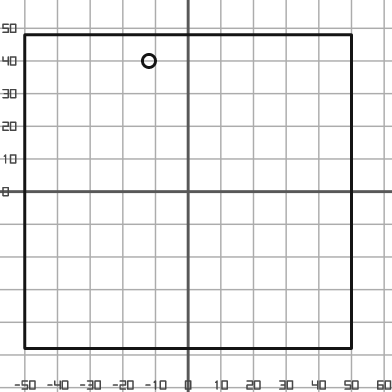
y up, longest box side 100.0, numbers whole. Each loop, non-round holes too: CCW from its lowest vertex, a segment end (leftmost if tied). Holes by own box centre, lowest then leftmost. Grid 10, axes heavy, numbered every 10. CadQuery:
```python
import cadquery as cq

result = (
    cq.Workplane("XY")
    .moveTo(-50.0, -48.0)
    .lineTo(50.0, -48.0)
    .lineTo(50.0, 48.0)
    .lineTo(-50.0, 48.0)
    .close()
    .moveTo(-12.0, 40.0)
    .circle(2.0)
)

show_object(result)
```